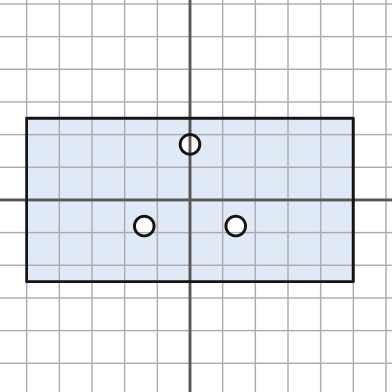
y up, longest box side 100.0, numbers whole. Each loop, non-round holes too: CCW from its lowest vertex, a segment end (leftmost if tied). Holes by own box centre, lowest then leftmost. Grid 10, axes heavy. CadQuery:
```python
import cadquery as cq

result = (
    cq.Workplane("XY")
    .moveTo(-50.0, -25.0)
    .lineTo(50.0, -25.0)
    .lineTo(50.0, 25.0)
    .lineTo(-50.0, 25.0)
    .close()
    .moveTo(-14.0, -8.0)
    .circle(3.0)
    .moveTo(14.0, -8.0)
    .circle(3.0)
    .moveTo(0.0, 17.0)
    .circle(3.0)
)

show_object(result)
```